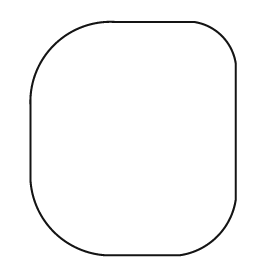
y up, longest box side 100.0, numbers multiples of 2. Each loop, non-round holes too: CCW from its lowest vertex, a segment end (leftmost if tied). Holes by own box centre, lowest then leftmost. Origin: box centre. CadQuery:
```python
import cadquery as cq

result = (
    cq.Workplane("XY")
    .moveTo(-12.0, -50.0)
    .lineTo(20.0, -50.0)
    .threePointArc((36.0, -42.0), (44.0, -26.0))
    .lineTo(44.0, 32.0)
    .threePointArc((38.0, 44.0), (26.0, 50.0))
    .lineTo(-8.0, 50.0)
    .threePointArc((-34.0, 40.0), (-44.0, 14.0))
    .lineTo(-44.0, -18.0)
    .threePointArc((-34.0, -40.0), (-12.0, -50.0))
    .close()
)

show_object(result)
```